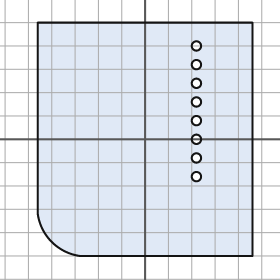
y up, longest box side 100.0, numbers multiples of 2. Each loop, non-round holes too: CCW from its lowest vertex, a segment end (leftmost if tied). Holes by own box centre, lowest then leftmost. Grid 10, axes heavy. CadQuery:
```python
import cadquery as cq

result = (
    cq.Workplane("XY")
    .moveTo(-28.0, -50.0)
    .lineTo(46.0, -50.0)
    .lineTo(46.0, 50.0)
    .lineTo(-46.0, 50.0)
    .lineTo(-46.0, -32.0)
    .threePointArc((-40.0, -44.0), (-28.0, -50.0))
    .close()
    .moveTo(22.0, -16.0)
    .circle(2.0)
    .moveTo(22.0, -8.0)
    .circle(2.0)
    .moveTo(22.0, 0.0)
    .circle(2.0)
    .moveTo(22.0, 8.0)
    .circle(2.0)
    .moveTo(22.0, 16.0)
    .circle(2.0)
    .moveTo(22.0, 24.0)
    .circle(2.0)
    .moveTo(22.0, 32.0)
    .circle(2.0)
    .moveTo(22.0, 40.0)
    .circle(2.0)
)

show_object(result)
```